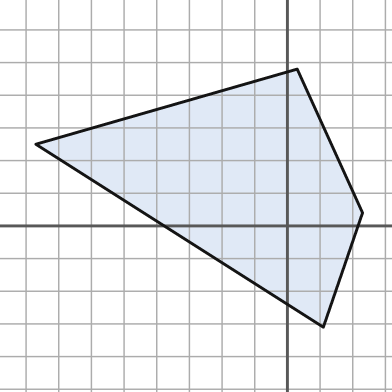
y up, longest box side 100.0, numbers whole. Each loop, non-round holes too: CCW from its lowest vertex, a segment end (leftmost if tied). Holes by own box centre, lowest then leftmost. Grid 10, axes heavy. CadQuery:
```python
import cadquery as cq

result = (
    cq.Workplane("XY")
    .moveTo(11.0, -31.0)
    .lineTo(23.0, 4.0)
    .lineTo(3.0, 48.0)
    .lineTo(-77.0, 25.0)
    .close()
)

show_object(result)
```